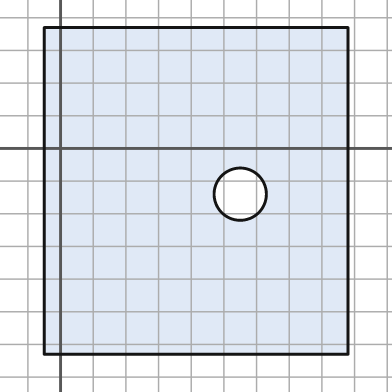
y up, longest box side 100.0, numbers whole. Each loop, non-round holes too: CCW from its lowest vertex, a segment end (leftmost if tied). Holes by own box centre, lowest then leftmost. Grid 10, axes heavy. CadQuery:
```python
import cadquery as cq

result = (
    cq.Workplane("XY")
    .moveTo(-5.0, -63.0)
    .lineTo(88.0, -63.0)
    .lineTo(88.0, 37.0)
    .lineTo(-5.0, 37.0)
    .close()
    .moveTo(55.0, -14.0)
    .circle(8.0)
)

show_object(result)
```